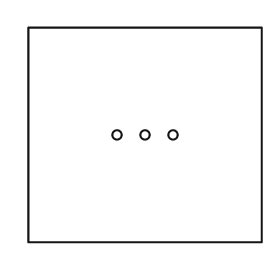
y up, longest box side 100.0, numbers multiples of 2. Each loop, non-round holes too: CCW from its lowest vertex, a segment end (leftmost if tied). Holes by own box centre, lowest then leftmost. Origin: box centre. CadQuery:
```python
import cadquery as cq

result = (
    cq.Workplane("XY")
    .moveTo(-50.0, -46.0)
    .lineTo(50.0, -46.0)
    .lineTo(50.0, 46.0)
    .lineTo(-50.0, 46.0)
    .close()
    .moveTo(-12.0, 0.0)
    .circle(2.0)
    .moveTo(0.0, 0.0)
    .circle(2.0)
    .moveTo(12.0, 0.0)
    .circle(2.0)
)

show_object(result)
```